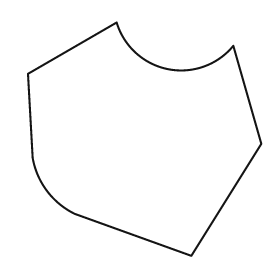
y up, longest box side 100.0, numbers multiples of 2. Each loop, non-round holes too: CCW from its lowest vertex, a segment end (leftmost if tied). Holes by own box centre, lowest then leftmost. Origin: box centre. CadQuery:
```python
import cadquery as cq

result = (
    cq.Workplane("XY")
    .moveTo(20.0, -50.0)
    .lineTo(50.0, -2.0)
    .lineTo(38.0, 40.0)
    .threePointArc((10.0, 30.0), (-12.0, 50.0))
    .lineTo(-50.0, 28.0)
    .lineTo(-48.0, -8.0)
    .threePointArc((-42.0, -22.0), (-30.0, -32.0))
    .close()
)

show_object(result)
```